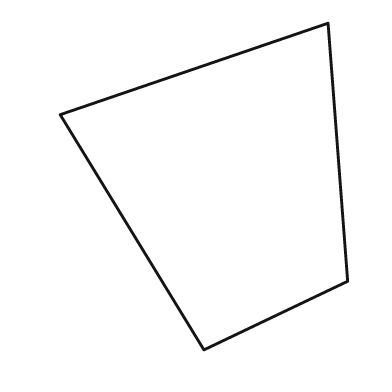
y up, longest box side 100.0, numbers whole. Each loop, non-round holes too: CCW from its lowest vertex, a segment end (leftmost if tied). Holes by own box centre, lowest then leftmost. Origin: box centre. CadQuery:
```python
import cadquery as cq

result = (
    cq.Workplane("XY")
    .moveTo(0.0, -50.0)
    .lineTo(44.0, -29.0)
    .lineTo(38.0, 50.0)
    .lineTo(-44.0, 22.0)
    .close()
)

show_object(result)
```